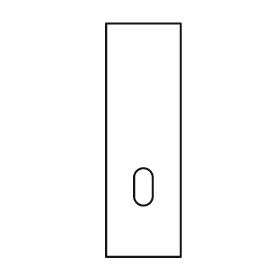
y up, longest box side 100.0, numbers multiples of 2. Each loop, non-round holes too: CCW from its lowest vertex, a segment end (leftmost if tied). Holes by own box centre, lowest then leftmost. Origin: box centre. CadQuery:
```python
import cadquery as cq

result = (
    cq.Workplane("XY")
    .moveTo(-16.0, -50.0)
    .lineTo(16.0, -50.0)
    .lineTo(16.0, 50.0)
    .lineTo(-16.0, 50.0)
    .close()
    .moveTo(-4.0, -24.0)
    .threePointArc((0.0, -28.0), (4.0, -24.0))
    .lineTo(4.0, -16.0)
    .threePointArc((0.0, -12.0), (-4.0, -16.0))
    .close()
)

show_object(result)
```